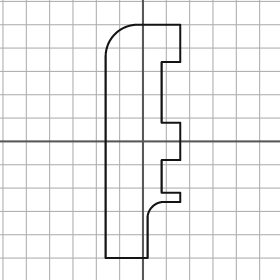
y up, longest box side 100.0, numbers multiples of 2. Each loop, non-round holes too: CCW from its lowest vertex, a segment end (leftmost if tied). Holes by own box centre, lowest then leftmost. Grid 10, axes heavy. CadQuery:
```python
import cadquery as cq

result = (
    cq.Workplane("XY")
    .moveTo(-16.0, -50.0)
    .lineTo(2.0, -50.0)
    .lineTo(2.0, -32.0)
    .threePointArc((4.0, -28.0), (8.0, -26.0))
    .lineTo(16.0, -26.0)
    .lineTo(16.0, -22.0)
    .lineTo(8.0, -22.0)
    .lineTo(8.0, -8.0)
    .lineTo(16.0, -8.0)
    .lineTo(16.0, 8.0)
    .lineTo(8.0, 8.0)
    .lineTo(8.0, 34.0)
    .lineTo(16.0, 34.0)
    .lineTo(16.0, 50.0)
    .lineTo(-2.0, 50.0)
    .threePointArc((-12.0, 46.0), (-16.0, 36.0))
    .close()
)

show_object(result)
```